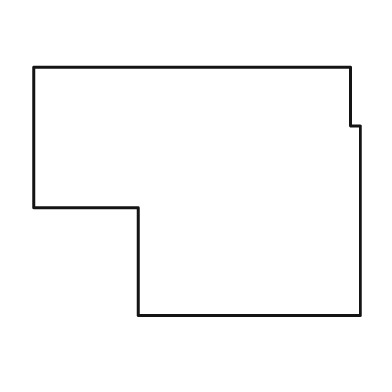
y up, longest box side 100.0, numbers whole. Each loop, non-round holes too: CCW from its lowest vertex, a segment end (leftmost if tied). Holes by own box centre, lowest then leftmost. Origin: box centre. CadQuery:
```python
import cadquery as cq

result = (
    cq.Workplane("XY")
    .moveTo(-18.0, -38.0)
    .lineTo(50.0, -38.0)
    .lineTo(50.0, 20.0)
    .lineTo(47.0, 20.0)
    .lineTo(47.0, 38.0)
    .lineTo(-50.0, 38.0)
    .lineTo(-50.0, -5.0)
    .lineTo(-18.0, -5.0)
    .close()
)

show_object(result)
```